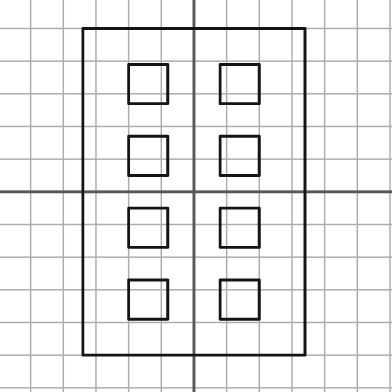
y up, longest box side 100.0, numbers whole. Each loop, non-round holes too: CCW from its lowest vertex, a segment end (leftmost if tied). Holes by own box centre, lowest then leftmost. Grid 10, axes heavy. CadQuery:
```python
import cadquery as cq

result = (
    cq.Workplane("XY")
    .moveTo(-34.0, -50.0)
    .lineTo(34.0, -50.0)
    .lineTo(34.0, 50.0)
    .lineTo(-34.0, 50.0)
    .close()
    .moveTo(-20.0, -39.0)
    .lineTo(-8.0, -39.0)
    .lineTo(-8.0, -27.0)
    .lineTo(-20.0, -27.0)
    .close()
    .moveTo(8.0, -39.0)
    .lineTo(20.0, -39.0)
    .lineTo(20.0, -27.0)
    .lineTo(8.0, -27.0)
    .close()
    .moveTo(-20.0, -17.0)
    .lineTo(-8.0, -17.0)
    .lineTo(-8.0, -5.0)
    .lineTo(-20.0, -5.0)
    .close()
    .moveTo(8.0, -17.0)
    .lineTo(20.0, -17.0)
    .lineTo(20.0, -5.0)
    .lineTo(8.0, -5.0)
    .close()
    .moveTo(-20.0, 5.0)
    .lineTo(-8.0, 5.0)
    .lineTo(-8.0, 17.0)
    .lineTo(-20.0, 17.0)
    .close()
    .moveTo(8.0, 5.0)
    .lineTo(20.0, 5.0)
    .lineTo(20.0, 17.0)
    .lineTo(8.0, 17.0)
    .close()
    .moveTo(-20.0, 27.0)
    .lineTo(-8.0, 27.0)
    .lineTo(-8.0, 39.0)
    .lineTo(-20.0, 39.0)
    .close()
    .moveTo(8.0, 27.0)
    .lineTo(20.0, 27.0)
    .lineTo(20.0, 39.0)
    .lineTo(8.0, 39.0)
    .close()
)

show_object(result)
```